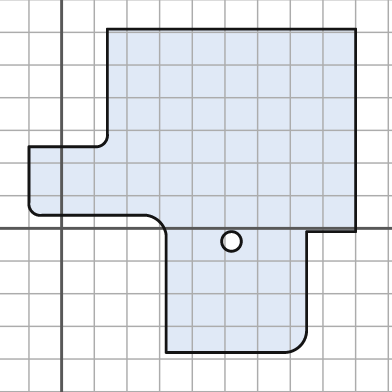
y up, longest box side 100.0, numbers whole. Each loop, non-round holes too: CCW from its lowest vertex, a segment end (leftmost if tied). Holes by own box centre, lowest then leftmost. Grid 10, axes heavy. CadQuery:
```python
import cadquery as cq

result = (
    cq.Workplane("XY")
    .moveTo(32.0, -38.0)
    .lineTo(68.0, -38.0)
    .threePointArc((73.0, -36.0), (75.0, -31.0))
    .lineTo(75.0, -1.0)
    .lineTo(90.0, -1.0)
    .lineTo(90.0, 61.0)
    .lineTo(14.0, 61.0)
    .lineTo(14.0, 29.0)
    .threePointArc((13.0, 26.0), (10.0, 25.0))
    .lineTo(-10.0, 25.0)
    .lineTo(-10.0, 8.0)
    .threePointArc((-9.0, 5.0), (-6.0, 4.0))
    .lineTo(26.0, 4.0)
    .threePointArc((30.0, 2.0), (32.0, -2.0))
    .close()
    .moveTo(52.0, -4.0)
    .circle(3.0)
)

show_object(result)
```